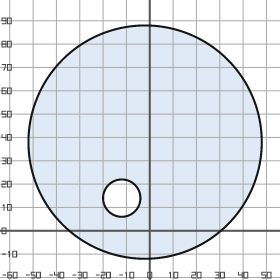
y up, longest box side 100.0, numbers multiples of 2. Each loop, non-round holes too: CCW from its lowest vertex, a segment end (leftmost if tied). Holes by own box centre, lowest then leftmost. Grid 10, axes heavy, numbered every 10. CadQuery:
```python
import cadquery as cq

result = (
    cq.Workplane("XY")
    .moveTo(-2.0, 38.0)
    .circle(50.0)
    .moveTo(-12.0, 14.0)
    .circle(8.0)
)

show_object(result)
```